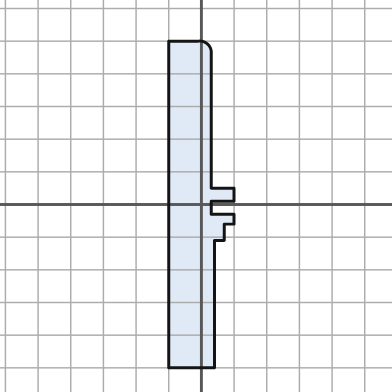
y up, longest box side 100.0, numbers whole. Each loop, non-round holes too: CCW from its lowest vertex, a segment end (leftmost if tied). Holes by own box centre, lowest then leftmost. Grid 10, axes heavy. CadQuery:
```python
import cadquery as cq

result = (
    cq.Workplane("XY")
    .moveTo(-10.0, -50.0)
    .lineTo(4.0, -50.0)
    .lineTo(4.0, -11.0)
    .lineTo(7.0, -11.0)
    .lineTo(7.0, -6.0)
    .lineTo(10.0, -6.0)
    .lineTo(10.0, -3.0)
    .lineTo(3.0, -3.0)
    .lineTo(3.0, 1.0)
    .lineTo(10.0, 1.0)
    .lineTo(10.0, 5.0)
    .lineTo(3.0, 5.0)
    .lineTo(3.0, 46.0)
    .threePointArc((2.0, 49.0), (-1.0, 50.0))
    .lineTo(-10.0, 50.0)
    .close()
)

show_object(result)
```